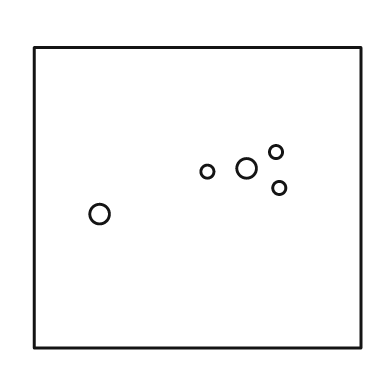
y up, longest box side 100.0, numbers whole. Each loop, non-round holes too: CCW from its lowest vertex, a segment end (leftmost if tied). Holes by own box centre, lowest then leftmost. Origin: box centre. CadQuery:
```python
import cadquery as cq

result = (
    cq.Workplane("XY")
    .moveTo(-50.0, -46.0)
    .lineTo(50.0, -46.0)
    .lineTo(50.0, 46.0)
    .lineTo(-50.0, 46.0)
    .close()
    .moveTo(-30.0, -5.0)
    .circle(3.0)
    .moveTo(25.0, 3.0)
    .circle(2.0)
    .moveTo(3.0, 8.0)
    .circle(2.0)
    .moveTo(15.0, 9.0)
    .circle(3.0)
    .moveTo(24.0, 14.0)
    .circle(2.0)
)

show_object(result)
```